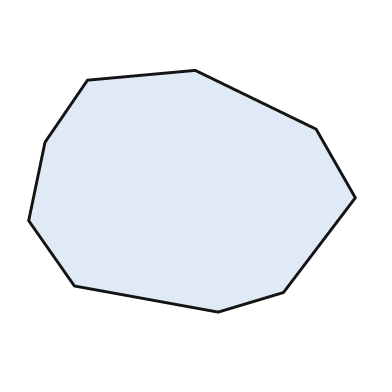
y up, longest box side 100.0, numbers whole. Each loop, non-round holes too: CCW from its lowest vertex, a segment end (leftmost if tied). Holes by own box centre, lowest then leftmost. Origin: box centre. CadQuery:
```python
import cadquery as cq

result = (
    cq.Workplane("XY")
    .moveTo(8.0, -37.0)
    .lineTo(28.0, -31.0)
    .lineTo(50.0, -2.0)
    .lineTo(38.0, 19.0)
    .lineTo(1.0, 37.0)
    .lineTo(-32.0, 34.0)
    .lineTo(-45.0, 15.0)
    .lineTo(-50.0, -9.0)
    .lineTo(-36.0, -29.0)
    .close()
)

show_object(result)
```